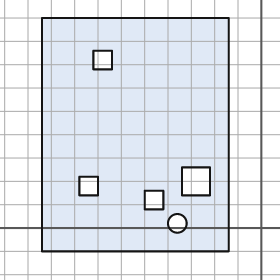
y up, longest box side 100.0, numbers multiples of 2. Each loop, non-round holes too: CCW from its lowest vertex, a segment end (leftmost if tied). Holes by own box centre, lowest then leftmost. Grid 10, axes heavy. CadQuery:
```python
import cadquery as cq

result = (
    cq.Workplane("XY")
    .moveTo(-94.0, -10.0)
    .lineTo(-14.0, -10.0)
    .lineTo(-14.0, 90.0)
    .lineTo(-94.0, 90.0)
    .close()
    .moveTo(-36.0, 2.0)
    .circle(4.0)
    .moveTo(-50.0, 8.0)
    .lineTo(-42.0, 8.0)
    .lineTo(-42.0, 16.0)
    .lineTo(-50.0, 16.0)
    .close()
    .moveTo(-78.0, 14.0)
    .lineTo(-70.0, 14.0)
    .lineTo(-70.0, 22.0)
    .lineTo(-78.0, 22.0)
    .close()
    .moveTo(-34.0, 14.0)
    .lineTo(-22.0, 14.0)
    .lineTo(-22.0, 26.0)
    .lineTo(-34.0, 26.0)
    .close()
    .moveTo(-72.0, 68.0)
    .lineTo(-64.0, 68.0)
    .lineTo(-64.0, 76.0)
    .lineTo(-72.0, 76.0)
    .close()
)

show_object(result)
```